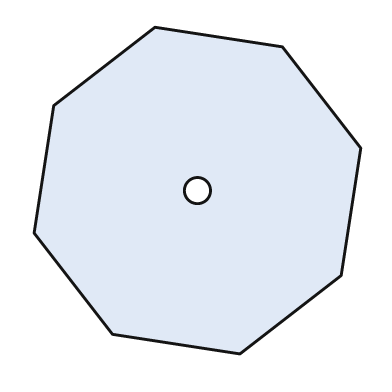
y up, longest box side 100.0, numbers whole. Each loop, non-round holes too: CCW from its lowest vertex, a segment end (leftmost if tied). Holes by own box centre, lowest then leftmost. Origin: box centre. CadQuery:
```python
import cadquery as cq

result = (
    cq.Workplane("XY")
    .moveTo(13.0, -50.0)
    .lineTo(44.0, -26.0)
    .lineTo(50.0, 13.0)
    .lineTo(26.0, 44.0)
    .lineTo(-13.0, 50.0)
    .lineTo(-44.0, 26.0)
    .lineTo(-50.0, -13.0)
    .lineTo(-26.0, -44.0)
    .close()
    .moveTo(0.0, 0.0)
    .circle(4.0)
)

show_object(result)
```